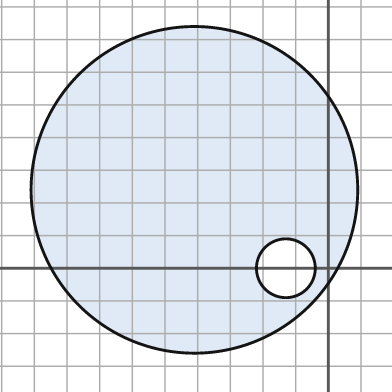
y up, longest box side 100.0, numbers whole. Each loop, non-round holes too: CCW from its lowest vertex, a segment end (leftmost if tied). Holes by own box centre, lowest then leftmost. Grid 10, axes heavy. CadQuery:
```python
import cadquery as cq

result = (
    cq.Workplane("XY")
    .moveTo(-41.0, 24.0)
    .circle(50.0)
    .moveTo(-13.0, 0.0)
    .circle(9.0)
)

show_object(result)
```